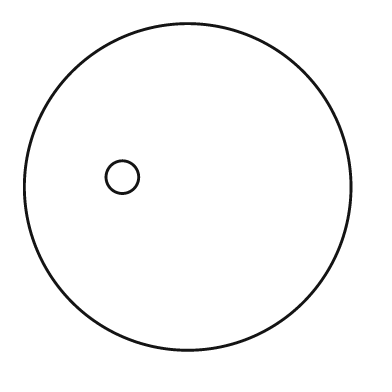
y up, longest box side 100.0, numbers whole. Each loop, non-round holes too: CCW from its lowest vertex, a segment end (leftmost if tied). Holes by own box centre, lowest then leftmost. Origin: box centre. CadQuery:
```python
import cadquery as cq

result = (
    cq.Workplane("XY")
    .moveTo(0.0, 0.0)
    .circle(50.0)
    .moveTo(-20.0, 3.0)
    .circle(5.0)
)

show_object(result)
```